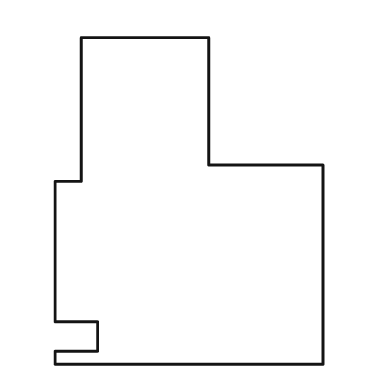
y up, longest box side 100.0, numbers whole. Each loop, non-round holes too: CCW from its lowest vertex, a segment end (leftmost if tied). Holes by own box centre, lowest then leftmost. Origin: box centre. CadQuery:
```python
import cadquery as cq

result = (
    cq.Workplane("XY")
    .moveTo(-41.0, -50.0)
    .lineTo(41.0, -50.0)
    .lineTo(41.0, 11.0)
    .lineTo(6.0, 11.0)
    .lineTo(6.0, 50.0)
    .lineTo(-33.0, 50.0)
    .lineTo(-33.0, 6.0)
    .lineTo(-41.0, 6.0)
    .lineTo(-41.0, -37.0)
    .lineTo(-28.0, -37.0)
    .lineTo(-28.0, -46.0)
    .lineTo(-41.0, -46.0)
    .close()
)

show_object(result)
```